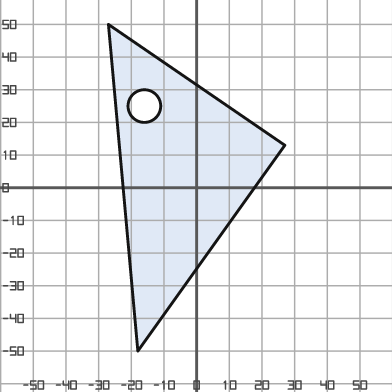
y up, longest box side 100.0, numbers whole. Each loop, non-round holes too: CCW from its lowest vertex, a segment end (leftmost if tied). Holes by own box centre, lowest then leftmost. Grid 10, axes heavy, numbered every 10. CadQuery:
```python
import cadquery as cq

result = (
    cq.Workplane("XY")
    .moveTo(-18.0, -50.0)
    .lineTo(27.0, 13.0)
    .lineTo(-27.0, 50.0)
    .close()
    .moveTo(-16.0, 25.0)
    .circle(5.0)
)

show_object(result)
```